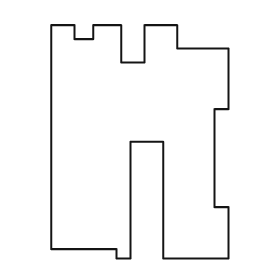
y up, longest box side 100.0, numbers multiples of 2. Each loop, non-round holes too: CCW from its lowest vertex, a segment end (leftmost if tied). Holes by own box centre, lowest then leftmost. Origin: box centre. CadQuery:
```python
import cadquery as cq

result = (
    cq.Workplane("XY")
    .moveTo(-10.0, -50.0)
    .lineTo(-4.0, -50.0)
    .lineTo(-4.0, 0.0)
    .lineTo(10.0, 0.0)
    .lineTo(10.0, -50.0)
    .lineTo(38.0, -50.0)
    .lineTo(38.0, -28.0)
    .lineTo(32.0, -28.0)
    .lineTo(32.0, 14.0)
    .lineTo(38.0, 14.0)
    .lineTo(38.0, 40.0)
    .lineTo(16.0, 40.0)
    .lineTo(16.0, 50.0)
    .lineTo(2.0, 50.0)
    .lineTo(2.0, 34.0)
    .lineTo(-8.0, 34.0)
    .lineTo(-8.0, 50.0)
    .lineTo(-20.0, 50.0)
    .lineTo(-20.0, 44.0)
    .lineTo(-28.0, 44.0)
    .lineTo(-28.0, 50.0)
    .lineTo(-38.0, 50.0)
    .lineTo(-38.0, -46.0)
    .lineTo(-10.0, -46.0)
    .close()
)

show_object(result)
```